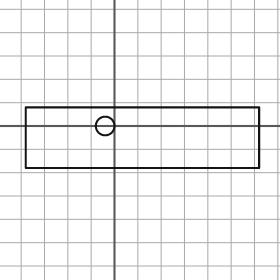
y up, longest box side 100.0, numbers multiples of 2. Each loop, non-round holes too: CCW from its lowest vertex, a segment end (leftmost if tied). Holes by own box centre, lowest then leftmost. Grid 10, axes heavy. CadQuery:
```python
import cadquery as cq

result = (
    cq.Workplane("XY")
    .moveTo(-38.0, -18.0)
    .lineTo(62.0, -18.0)
    .lineTo(62.0, 8.0)
    .lineTo(-38.0, 8.0)
    .close()
    .moveTo(-4.0, 0.0)
    .circle(4.0)
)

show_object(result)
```